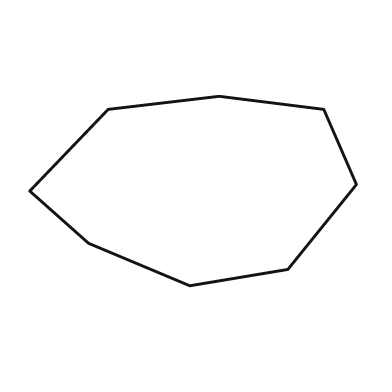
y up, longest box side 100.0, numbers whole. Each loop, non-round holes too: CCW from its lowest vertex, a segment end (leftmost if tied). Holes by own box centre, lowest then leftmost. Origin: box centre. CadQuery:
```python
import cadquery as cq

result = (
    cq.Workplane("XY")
    .moveTo(-1.0, -29.0)
    .lineTo(29.0, -24.0)
    .lineTo(50.0, 2.0)
    .lineTo(40.0, 25.0)
    .lineTo(8.0, 29.0)
    .lineTo(-26.0, 25.0)
    .lineTo(-50.0, 0.0)
    .lineTo(-32.0, -16.0)
    .close()
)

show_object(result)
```